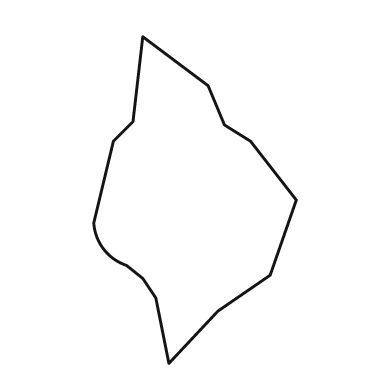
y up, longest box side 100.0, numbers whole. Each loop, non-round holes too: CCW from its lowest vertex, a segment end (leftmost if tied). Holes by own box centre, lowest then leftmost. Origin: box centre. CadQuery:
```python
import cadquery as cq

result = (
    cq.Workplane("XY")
    .moveTo(-8.0, -50.0)
    .lineTo(7.0, -34.0)
    .lineTo(23.0, -23.0)
    .lineTo(31.0, 0.0)
    .lineTo(17.0, 18.0)
    .lineTo(9.0, 23.0)
    .lineTo(4.0, 35.0)
    .lineTo(-16.0, 50.0)
    .lineTo(-19.0, 24.0)
    .lineTo(-25.0, 18.0)
    .lineTo(-31.0, -7.0)
    .threePointArc((-28.0, -15.0), (-21.0, -20.0))
    .lineTo(-16.0, -24.0)
    .lineTo(-12.0, -30.0)
    .close()
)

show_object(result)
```